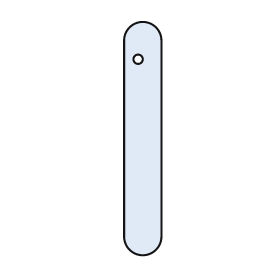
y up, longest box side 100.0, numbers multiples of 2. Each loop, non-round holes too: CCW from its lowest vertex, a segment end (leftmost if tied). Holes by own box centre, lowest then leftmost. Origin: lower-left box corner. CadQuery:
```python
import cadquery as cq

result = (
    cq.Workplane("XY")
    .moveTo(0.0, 8.0)
    .threePointArc((8.0, 0.0), (16.0, 8.0))
    .lineTo(16.0, 92.0)
    .threePointArc((8.0, 100.0), (0.0, 92.0))
    .close()
    .moveTo(6.0, 84.0)
    .circle(2.0)
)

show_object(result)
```